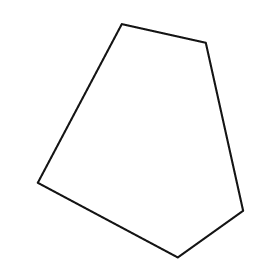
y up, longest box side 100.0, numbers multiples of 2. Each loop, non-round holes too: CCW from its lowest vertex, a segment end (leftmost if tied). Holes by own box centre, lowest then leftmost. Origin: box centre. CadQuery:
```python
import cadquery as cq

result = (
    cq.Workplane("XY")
    .moveTo(16.0, -50.0)
    .lineTo(44.0, -30.0)
    .lineTo(28.0, 42.0)
    .lineTo(-8.0, 50.0)
    .lineTo(-44.0, -18.0)
    .close()
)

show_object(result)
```